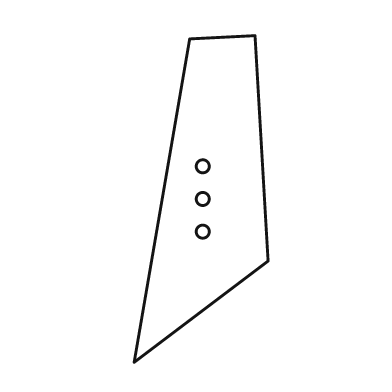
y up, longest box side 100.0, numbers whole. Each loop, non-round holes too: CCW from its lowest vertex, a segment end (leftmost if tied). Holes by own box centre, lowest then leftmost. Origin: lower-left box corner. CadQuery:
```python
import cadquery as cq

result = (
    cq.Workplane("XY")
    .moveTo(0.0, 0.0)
    .lineTo(41.0, 31.0)
    .lineTo(37.0, 100.0)
    .lineTo(17.0, 99.0)
    .close()
    .moveTo(21.0, 40.0)
    .circle(2.0)
    .moveTo(21.0, 50.0)
    .circle(2.0)
    .moveTo(21.0, 60.0)
    .circle(2.0)
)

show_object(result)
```